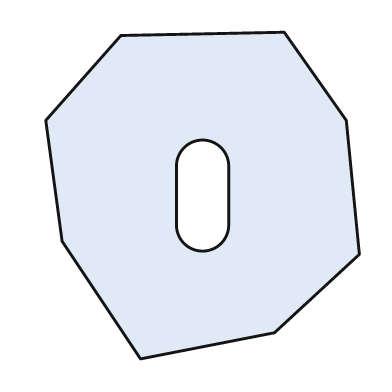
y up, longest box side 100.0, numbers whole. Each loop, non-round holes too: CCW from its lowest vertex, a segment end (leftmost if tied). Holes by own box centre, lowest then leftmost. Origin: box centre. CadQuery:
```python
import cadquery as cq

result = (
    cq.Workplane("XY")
    .moveTo(-19.0, -50.0)
    .lineTo(22.0, -42.0)
    .lineTo(48.0, -18.0)
    .lineTo(44.0, 23.0)
    .lineTo(25.0, 50.0)
    .lineTo(-25.0, 49.0)
    .lineTo(-48.0, 23.0)
    .lineTo(-43.0, -14.0)
    .close()
    .moveTo(-8.0, -9.0)
    .threePointArc((0.0, -17.0), (8.0, -9.0))
    .lineTo(8.0, 9.0)
    .threePointArc((0.0, 17.0), (-8.0, 9.0))
    .close()
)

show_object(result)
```